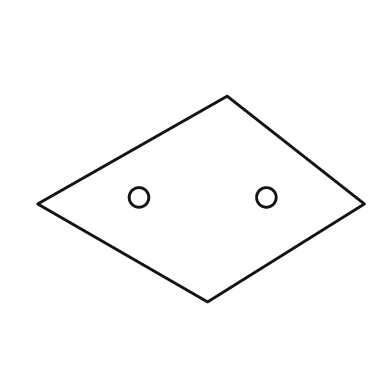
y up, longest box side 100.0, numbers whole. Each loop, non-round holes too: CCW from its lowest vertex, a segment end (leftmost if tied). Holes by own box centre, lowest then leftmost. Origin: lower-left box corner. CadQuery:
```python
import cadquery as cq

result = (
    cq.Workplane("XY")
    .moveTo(52.0, 0.0)
    .lineTo(100.0, 30.0)
    .lineTo(58.0, 63.0)
    .lineTo(0.0, 30.0)
    .close()
    .moveTo(31.0, 32.0)
    .circle(3.0)
    .moveTo(70.0, 32.0)
    .circle(3.0)
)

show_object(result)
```